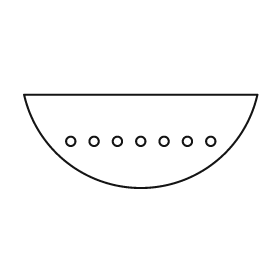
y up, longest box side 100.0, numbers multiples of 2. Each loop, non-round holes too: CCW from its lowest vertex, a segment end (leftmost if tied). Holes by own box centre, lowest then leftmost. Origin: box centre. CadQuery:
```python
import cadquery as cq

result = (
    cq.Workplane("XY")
    .moveTo(-50.0, 20.0)
    .threePointArc((0.0, -20.0), (50.0, 20.0))
    .close()
    .moveTo(-30.0, 0.0)
    .circle(2.0)
    .moveTo(-20.0, 0.0)
    .circle(2.0)
    .moveTo(-10.0, 0.0)
    .circle(2.0)
    .moveTo(0.0, 0.0)
    .circle(2.0)
    .moveTo(10.0, 0.0)
    .circle(2.0)
    .moveTo(20.0, 0.0)
    .circle(2.0)
    .moveTo(30.0, 0.0)
    .circle(2.0)
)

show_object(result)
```